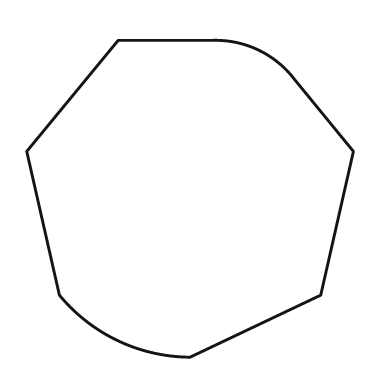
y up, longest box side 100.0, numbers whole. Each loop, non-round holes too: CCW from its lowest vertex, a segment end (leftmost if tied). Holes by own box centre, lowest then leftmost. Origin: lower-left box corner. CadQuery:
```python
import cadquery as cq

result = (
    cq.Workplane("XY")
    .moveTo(50.0, 0.0)
    .lineTo(90.0, 19.0)
    .lineTo(100.0, 63.0)
    .lineTo(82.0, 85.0)
    .threePointArc((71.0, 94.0), (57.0, 97.0))
    .lineTo(28.0, 97.0)
    .lineTo(0.0, 63.0)
    .lineTo(10.0, 19.0)
    .threePointArc((28.0, 5.0), (50.0, 0.0))
    .close()
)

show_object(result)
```